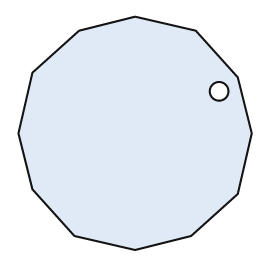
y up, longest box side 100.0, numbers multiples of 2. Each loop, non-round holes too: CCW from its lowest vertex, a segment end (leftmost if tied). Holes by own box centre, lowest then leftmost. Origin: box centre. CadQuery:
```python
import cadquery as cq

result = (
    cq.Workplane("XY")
    .moveTo(0.0, -50.0)
    .lineTo(24.0, -44.0)
    .lineTo(44.0, -26.0)
    .lineTo(50.0, 0.0)
    .lineTo(44.0, 24.0)
    .lineTo(26.0, 44.0)
    .lineTo(0.0, 50.0)
    .lineTo(-24.0, 44.0)
    .lineTo(-44.0, 26.0)
    .lineTo(-50.0, 0.0)
    .lineTo(-44.0, -24.0)
    .lineTo(-26.0, -44.0)
    .close()
    .moveTo(36.0, 18.0)
    .circle(4.0)
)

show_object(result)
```